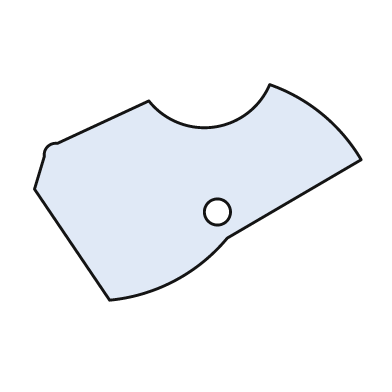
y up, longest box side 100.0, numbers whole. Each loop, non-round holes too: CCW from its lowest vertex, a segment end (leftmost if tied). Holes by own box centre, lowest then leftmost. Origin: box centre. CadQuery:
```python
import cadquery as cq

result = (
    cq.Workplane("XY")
    .moveTo(-27.0, -33.0)
    .threePointArc((-7.0, -27.0), (9.0, -14.0))
    .lineTo(50.0, 10.0)
    .threePointArc((38.0, 24.0), (22.0, 33.0))
    .threePointArc((5.0, 20.0), (-15.0, 28.0))
    .lineTo(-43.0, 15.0)
    .threePointArc((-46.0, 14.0), (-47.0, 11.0))
    .lineTo(-50.0, 1.0)
    .close()
    .moveTo(6.0, -6.0)
    .circle(4.0)
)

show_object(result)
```